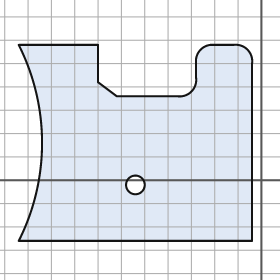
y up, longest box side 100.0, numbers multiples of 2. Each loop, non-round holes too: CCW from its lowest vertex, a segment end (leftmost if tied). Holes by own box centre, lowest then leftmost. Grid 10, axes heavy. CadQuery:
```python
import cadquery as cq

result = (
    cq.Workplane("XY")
    .moveTo(-104.0, -26.0)
    .lineTo(-4.0, -26.0)
    .lineTo(-4.0, 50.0)
    .threePointArc((-6.0, 56.0), (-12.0, 58.0))
    .lineTo(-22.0, 58.0)
    .threePointArc((-26.0, 56.0), (-28.0, 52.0))
    .lineTo(-28.0, 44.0)
    .threePointArc((-30.0, 38.0), (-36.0, 36.0))
    .lineTo(-62.0, 36.0)
    .lineTo(-70.0, 42.0)
    .lineTo(-70.0, 58.0)
    .lineTo(-104.0, 58.0)
    .threePointArc((-94.0, 16.0), (-104.0, -26.0))
    .close()
    .moveTo(-54.0, -2.0)
    .circle(4.0)
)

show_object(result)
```